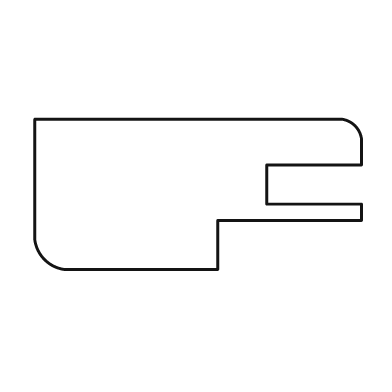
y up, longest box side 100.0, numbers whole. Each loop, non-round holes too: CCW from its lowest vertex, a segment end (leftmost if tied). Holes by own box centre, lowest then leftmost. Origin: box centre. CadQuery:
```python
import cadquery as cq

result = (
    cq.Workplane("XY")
    .moveTo(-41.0, -23.0)
    .lineTo(6.0, -23.0)
    .lineTo(6.0, -8.0)
    .lineTo(50.0, -8.0)
    .lineTo(50.0, -3.0)
    .lineTo(21.0, -3.0)
    .lineTo(21.0, 9.0)
    .lineTo(50.0, 9.0)
    .lineTo(50.0, 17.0)
    .threePointArc((48.0, 21.0), (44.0, 23.0))
    .lineTo(-50.0, 23.0)
    .lineTo(-50.0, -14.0)
    .threePointArc((-47.0, -20.0), (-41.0, -23.0))
    .close()
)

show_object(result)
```